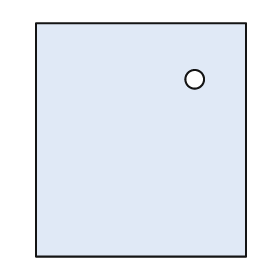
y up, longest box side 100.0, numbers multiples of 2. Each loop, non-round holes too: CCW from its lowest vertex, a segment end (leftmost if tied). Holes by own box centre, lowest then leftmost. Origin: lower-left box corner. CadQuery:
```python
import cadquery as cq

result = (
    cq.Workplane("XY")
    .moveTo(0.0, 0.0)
    .lineTo(90.0, 0.0)
    .lineTo(90.0, 100.0)
    .lineTo(0.0, 100.0)
    .close()
    .moveTo(68.0, 76.0)
    .circle(4.0)
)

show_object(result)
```